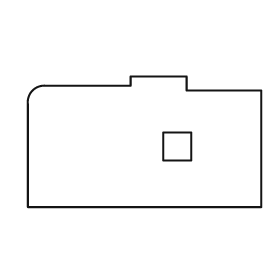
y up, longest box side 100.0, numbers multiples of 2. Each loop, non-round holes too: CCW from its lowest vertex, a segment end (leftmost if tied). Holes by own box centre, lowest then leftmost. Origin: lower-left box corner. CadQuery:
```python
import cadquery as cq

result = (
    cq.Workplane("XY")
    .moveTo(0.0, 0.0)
    .lineTo(100.0, 0.0)
    .lineTo(100.0, 50.0)
    .lineTo(68.0, 50.0)
    .lineTo(68.0, 56.0)
    .lineTo(44.0, 56.0)
    .lineTo(44.0, 52.0)
    .lineTo(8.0, 52.0)
    .threePointArc((2.0, 50.0), (0.0, 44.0))
    .close()
    .moveTo(58.0, 20.0)
    .lineTo(70.0, 20.0)
    .lineTo(70.0, 32.0)
    .lineTo(58.0, 32.0)
    .close()
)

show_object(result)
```